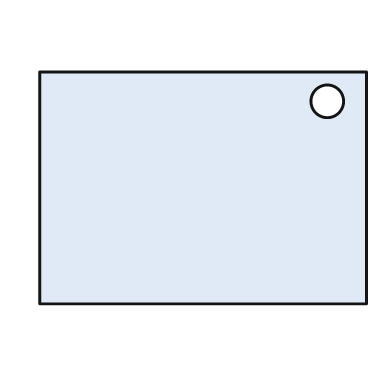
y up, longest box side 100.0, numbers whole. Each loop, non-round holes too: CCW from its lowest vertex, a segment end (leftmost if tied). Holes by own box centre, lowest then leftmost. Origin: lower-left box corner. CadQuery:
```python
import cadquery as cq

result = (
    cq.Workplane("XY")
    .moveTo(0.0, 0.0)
    .lineTo(100.0, 0.0)
    .lineTo(100.0, 71.0)
    .lineTo(0.0, 71.0)
    .close()
    .moveTo(88.0, 62.0)
    .circle(5.0)
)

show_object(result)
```